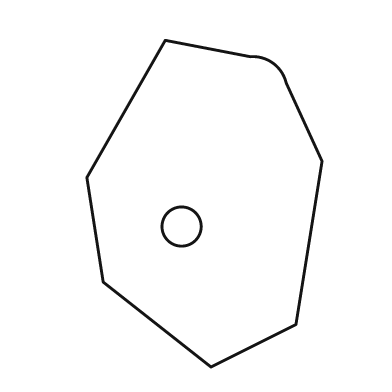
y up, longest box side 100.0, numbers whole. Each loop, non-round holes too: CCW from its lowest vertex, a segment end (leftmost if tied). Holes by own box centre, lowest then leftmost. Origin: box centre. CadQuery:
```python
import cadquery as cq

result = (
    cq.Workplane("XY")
    .moveTo(2.0, -50.0)
    .lineTo(28.0, -37.0)
    .lineTo(36.0, 13.0)
    .lineTo(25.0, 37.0)
    .threePointArc((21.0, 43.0), (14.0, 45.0))
    .lineTo(-12.0, 50.0)
    .lineTo(-36.0, 8.0)
    .lineTo(-31.0, -24.0)
    .close()
    .moveTo(-7.0, -7.0)
    .circle(6.0)
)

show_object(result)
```